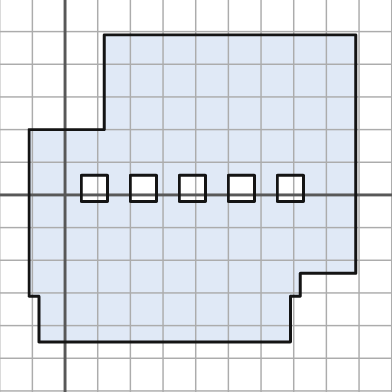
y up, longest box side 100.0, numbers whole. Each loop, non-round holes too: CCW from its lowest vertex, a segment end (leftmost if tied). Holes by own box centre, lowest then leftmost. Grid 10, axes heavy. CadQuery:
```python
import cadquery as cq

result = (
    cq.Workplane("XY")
    .moveTo(-8.0, -45.0)
    .lineTo(69.0, -45.0)
    .lineTo(69.0, -31.0)
    .lineTo(72.0, -31.0)
    .lineTo(72.0, -24.0)
    .lineTo(89.0, -24.0)
    .lineTo(89.0, 49.0)
    .lineTo(12.0, 49.0)
    .lineTo(12.0, 20.0)
    .lineTo(-11.0, 20.0)
    .lineTo(-11.0, -31.0)
    .lineTo(-8.0, -31.0)
    .close()
    .moveTo(5.0, -2.0)
    .lineTo(13.0, -2.0)
    .lineTo(13.0, 6.0)
    .lineTo(5.0, 6.0)
    .close()
    .moveTo(20.0, -2.0)
    .lineTo(28.0, -2.0)
    .lineTo(28.0, 6.0)
    .lineTo(20.0, 6.0)
    .close()
    .moveTo(35.0, -2.0)
    .lineTo(43.0, -2.0)
    .lineTo(43.0, 6.0)
    .lineTo(35.0, 6.0)
    .close()
    .moveTo(50.0, -2.0)
    .lineTo(58.0, -2.0)
    .lineTo(58.0, 6.0)
    .lineTo(50.0, 6.0)
    .close()
    .moveTo(65.0, -2.0)
    .lineTo(73.0, -2.0)
    .lineTo(73.0, 6.0)
    .lineTo(65.0, 6.0)
    .close()
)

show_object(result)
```